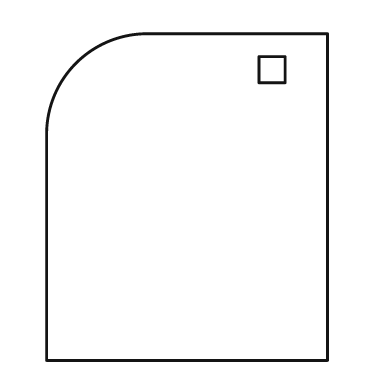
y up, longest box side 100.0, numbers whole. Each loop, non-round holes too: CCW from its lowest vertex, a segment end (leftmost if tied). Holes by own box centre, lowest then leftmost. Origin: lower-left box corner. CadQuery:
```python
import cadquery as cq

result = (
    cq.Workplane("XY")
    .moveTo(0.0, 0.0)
    .lineTo(86.0, 0.0)
    .lineTo(86.0, 100.0)
    .lineTo(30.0, 100.0)
    .threePointArc((9.0, 91.0), (0.0, 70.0))
    .close()
    .moveTo(65.0, 85.0)
    .lineTo(73.0, 85.0)
    .lineTo(73.0, 93.0)
    .lineTo(65.0, 93.0)
    .close()
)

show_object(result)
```